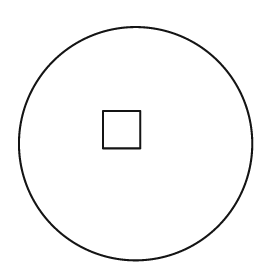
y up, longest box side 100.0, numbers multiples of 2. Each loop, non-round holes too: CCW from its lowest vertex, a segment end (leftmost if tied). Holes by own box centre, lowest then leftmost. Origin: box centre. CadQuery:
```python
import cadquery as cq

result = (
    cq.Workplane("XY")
    .moveTo(0.0, 0.0)
    .circle(50.0)
    .moveTo(-14.0, -2.0)
    .lineTo(2.0, -2.0)
    .lineTo(2.0, 14.0)
    .lineTo(-14.0, 14.0)
    .close()
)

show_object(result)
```